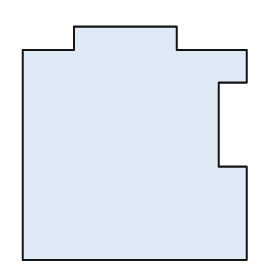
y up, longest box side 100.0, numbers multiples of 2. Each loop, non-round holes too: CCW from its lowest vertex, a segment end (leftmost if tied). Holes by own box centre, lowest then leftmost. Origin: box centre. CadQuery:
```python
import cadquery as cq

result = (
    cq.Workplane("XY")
    .moveTo(-48.0, -50.0)
    .lineTo(48.0, -50.0)
    .lineTo(48.0, -10.0)
    .lineTo(36.0, -10.0)
    .lineTo(36.0, 26.0)
    .lineTo(48.0, 26.0)
    .lineTo(48.0, 40.0)
    .lineTo(18.0, 40.0)
    .lineTo(18.0, 50.0)
    .lineTo(-26.0, 50.0)
    .lineTo(-26.0, 40.0)
    .lineTo(-48.0, 40.0)
    .close()
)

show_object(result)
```